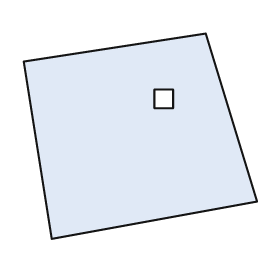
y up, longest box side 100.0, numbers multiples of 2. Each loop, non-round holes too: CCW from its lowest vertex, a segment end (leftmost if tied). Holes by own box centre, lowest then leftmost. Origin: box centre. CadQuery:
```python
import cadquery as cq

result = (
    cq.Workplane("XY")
    .moveTo(-38.0, -44.0)
    .lineTo(50.0, -28.0)
    .lineTo(28.0, 44.0)
    .lineTo(-50.0, 32.0)
    .close()
    .moveTo(6.0, 12.0)
    .lineTo(14.0, 12.0)
    .lineTo(14.0, 20.0)
    .lineTo(6.0, 20.0)
    .close()
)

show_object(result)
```